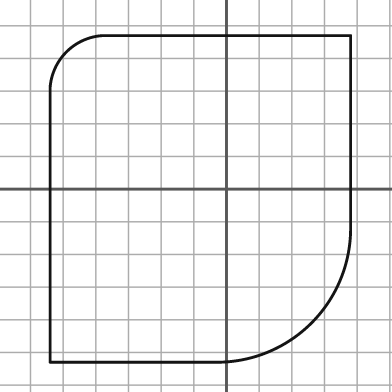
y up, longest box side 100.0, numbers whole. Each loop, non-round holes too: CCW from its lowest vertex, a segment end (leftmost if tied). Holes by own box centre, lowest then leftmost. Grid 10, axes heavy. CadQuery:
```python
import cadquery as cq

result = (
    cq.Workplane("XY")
    .moveTo(-54.0, -53.0)
    .lineTo(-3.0, -53.0)
    .threePointArc((26.0, -41.0), (38.0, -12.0))
    .lineTo(38.0, 47.0)
    .lineTo(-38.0, 47.0)
    .threePointArc((-49.0, 42.0), (-54.0, 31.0))
    .close()
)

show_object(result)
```